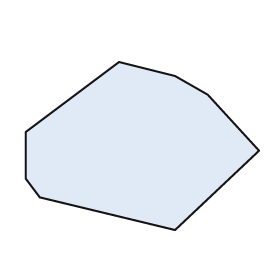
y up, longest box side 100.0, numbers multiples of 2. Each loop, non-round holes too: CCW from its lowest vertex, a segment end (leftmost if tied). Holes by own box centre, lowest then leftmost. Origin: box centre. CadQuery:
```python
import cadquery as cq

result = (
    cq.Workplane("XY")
    .moveTo(14.0, -36.0)
    .lineTo(50.0, -2.0)
    .lineTo(28.0, 22.0)
    .lineTo(14.0, 30.0)
    .lineTo(-10.0, 36.0)
    .lineTo(-50.0, 6.0)
    .lineTo(-50.0, -14.0)
    .lineTo(-44.0, -22.0)
    .close()
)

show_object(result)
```